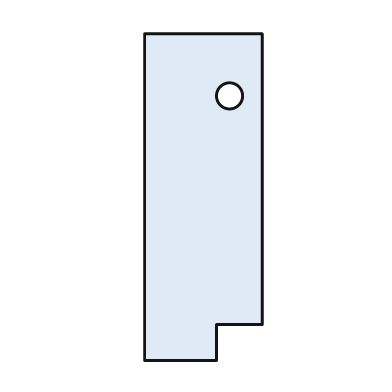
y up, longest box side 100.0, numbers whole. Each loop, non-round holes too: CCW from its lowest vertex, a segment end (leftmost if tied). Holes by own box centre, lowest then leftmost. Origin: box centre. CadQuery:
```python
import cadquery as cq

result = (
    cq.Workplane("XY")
    .moveTo(-18.0, -50.0)
    .lineTo(4.0, -50.0)
    .lineTo(4.0, -39.0)
    .lineTo(18.0, -39.0)
    .lineTo(18.0, 50.0)
    .lineTo(-18.0, 50.0)
    .close()
    .moveTo(8.0, 31.0)
    .circle(4.0)
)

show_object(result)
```